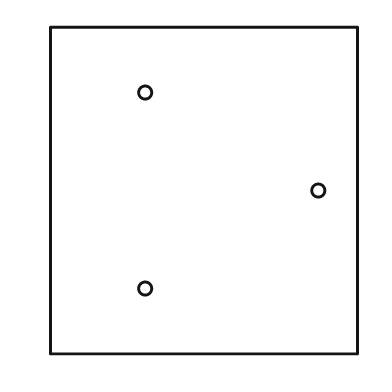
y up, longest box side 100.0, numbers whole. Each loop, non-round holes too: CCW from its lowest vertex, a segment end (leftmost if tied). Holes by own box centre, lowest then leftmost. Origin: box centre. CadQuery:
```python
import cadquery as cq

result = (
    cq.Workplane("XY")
    .moveTo(-47.0, -50.0)
    .lineTo(47.0, -50.0)
    .lineTo(47.0, 50.0)
    .lineTo(-47.0, 50.0)
    .close()
    .moveTo(-18.0, -30.0)
    .circle(2.0)
    .moveTo(35.0, 0.0)
    .circle(2.0)
    .moveTo(-18.0, 30.0)
    .circle(2.0)
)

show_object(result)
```